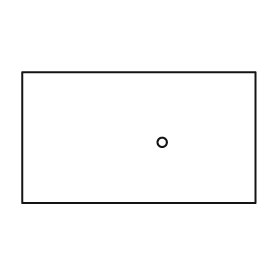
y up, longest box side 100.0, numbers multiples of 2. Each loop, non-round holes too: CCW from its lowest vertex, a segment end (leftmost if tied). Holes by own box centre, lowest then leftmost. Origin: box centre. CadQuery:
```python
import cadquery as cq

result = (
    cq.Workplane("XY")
    .moveTo(-50.0, -28.0)
    .lineTo(50.0, -28.0)
    .lineTo(50.0, 28.0)
    .lineTo(-50.0, 28.0)
    .close()
    .moveTo(10.0, -2.0)
    .circle(2.0)
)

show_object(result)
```